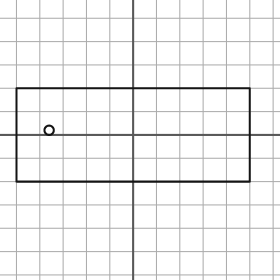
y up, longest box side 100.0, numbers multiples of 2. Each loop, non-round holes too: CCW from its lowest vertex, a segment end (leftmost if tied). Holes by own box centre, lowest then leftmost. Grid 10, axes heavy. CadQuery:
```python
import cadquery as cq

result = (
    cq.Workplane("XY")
    .moveTo(-50.0, -20.0)
    .lineTo(50.0, -20.0)
    .lineTo(50.0, 20.0)
    .lineTo(-50.0, 20.0)
    .close()
    .moveTo(-36.0, 2.0)
    .circle(2.0)
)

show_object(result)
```